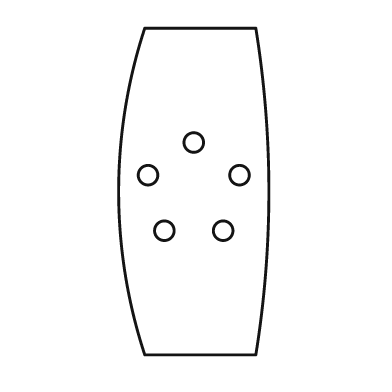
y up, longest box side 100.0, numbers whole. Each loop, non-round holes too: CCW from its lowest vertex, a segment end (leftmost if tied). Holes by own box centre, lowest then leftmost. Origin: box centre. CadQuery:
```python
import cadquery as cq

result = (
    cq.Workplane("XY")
    .moveTo(-15.0, -50.0)
    .lineTo(19.0, -50.0)
    .threePointArc((23.0, 0.0), (19.0, 50.0))
    .lineTo(-15.0, 50.0)
    .threePointArc((-23.0, 0.0), (-15.0, -50.0))
    .close()
    .moveTo(-9.0, -12.0)
    .circle(3.0)
    .moveTo(9.0, -12.0)
    .circle(3.0)
    .moveTo(-14.0, 5.0)
    .circle(3.0)
    .moveTo(14.0, 5.0)
    .circle(3.0)
    .moveTo(0.0, 15.0)
    .circle(3.0)
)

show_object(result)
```